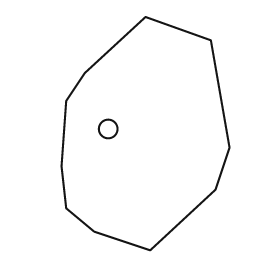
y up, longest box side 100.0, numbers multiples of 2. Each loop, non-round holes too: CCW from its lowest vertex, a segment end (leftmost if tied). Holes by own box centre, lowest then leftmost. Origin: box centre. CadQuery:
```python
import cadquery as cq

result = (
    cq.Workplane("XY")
    .moveTo(2.0, -50.0)
    .lineTo(30.0, -24.0)
    .lineTo(36.0, -6.0)
    .lineTo(28.0, 40.0)
    .lineTo(0.0, 50.0)
    .lineTo(-26.0, 26.0)
    .lineTo(-34.0, 14.0)
    .lineTo(-36.0, -14.0)
    .lineTo(-34.0, -32.0)
    .lineTo(-22.0, -42.0)
    .close()
    .moveTo(-16.0, 2.0)
    .circle(4.0)
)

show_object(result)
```